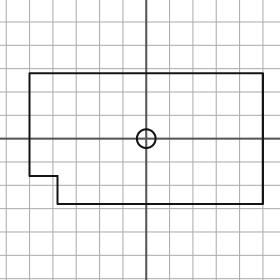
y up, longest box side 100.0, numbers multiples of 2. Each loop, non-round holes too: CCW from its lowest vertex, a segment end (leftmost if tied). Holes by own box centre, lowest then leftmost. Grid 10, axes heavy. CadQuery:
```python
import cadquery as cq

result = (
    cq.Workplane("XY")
    .moveTo(-38.0, -28.0)
    .lineTo(50.0, -28.0)
    .lineTo(50.0, 28.0)
    .lineTo(-50.0, 28.0)
    .lineTo(-50.0, -16.0)
    .lineTo(-38.0, -16.0)
    .close()
    .moveTo(0.0, 0.0)
    .circle(4.0)
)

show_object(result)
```